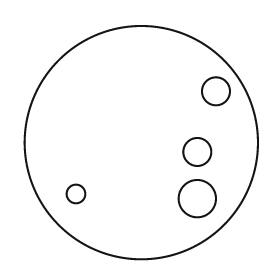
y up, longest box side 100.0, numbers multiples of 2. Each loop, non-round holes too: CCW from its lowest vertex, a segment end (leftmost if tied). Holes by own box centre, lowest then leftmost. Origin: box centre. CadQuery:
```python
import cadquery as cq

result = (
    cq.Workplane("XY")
    .moveTo(0.0, 0.0)
    .circle(50.0)
    .moveTo(24.0, -24.0)
    .circle(8.0)
    .moveTo(-28.0, -22.0)
    .circle(4.0)
    .moveTo(24.0, -4.0)
    .circle(6.0)
    .moveTo(32.0, 22.0)
    .circle(6.0)
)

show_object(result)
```